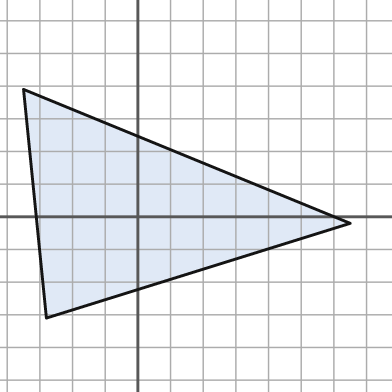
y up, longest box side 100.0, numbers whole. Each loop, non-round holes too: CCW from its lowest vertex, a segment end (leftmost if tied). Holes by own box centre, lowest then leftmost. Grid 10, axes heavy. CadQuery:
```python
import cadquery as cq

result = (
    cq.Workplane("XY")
    .moveTo(-28.0, -31.0)
    .lineTo(65.0, -2.0)
    .lineTo(-35.0, 39.0)
    .close()
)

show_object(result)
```